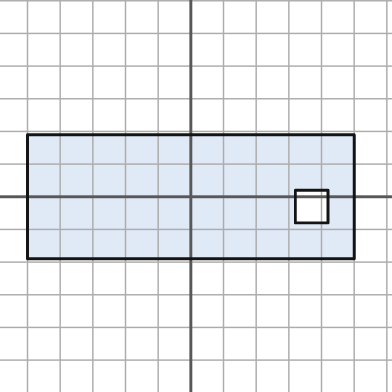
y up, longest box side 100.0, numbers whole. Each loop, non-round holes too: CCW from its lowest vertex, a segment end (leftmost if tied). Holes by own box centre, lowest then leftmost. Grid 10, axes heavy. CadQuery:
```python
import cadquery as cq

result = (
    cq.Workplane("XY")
    .moveTo(-50.0, -19.0)
    .lineTo(50.0, -19.0)
    .lineTo(50.0, 19.0)
    .lineTo(-50.0, 19.0)
    .close()
    .moveTo(32.0, -8.0)
    .lineTo(42.0, -8.0)
    .lineTo(42.0, 2.0)
    .lineTo(32.0, 2.0)
    .close()
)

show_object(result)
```